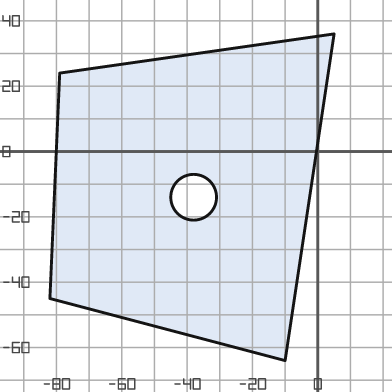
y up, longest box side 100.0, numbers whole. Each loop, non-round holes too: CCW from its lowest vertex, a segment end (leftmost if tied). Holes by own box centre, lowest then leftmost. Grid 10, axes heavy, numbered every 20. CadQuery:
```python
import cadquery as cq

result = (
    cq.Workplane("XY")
    .moveTo(-10.0, -64.0)
    .lineTo(5.0, 36.0)
    .lineTo(-79.0, 24.0)
    .lineTo(-82.0, -45.0)
    .close()
    .moveTo(-38.0, -14.0)
    .circle(7.0)
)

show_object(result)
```